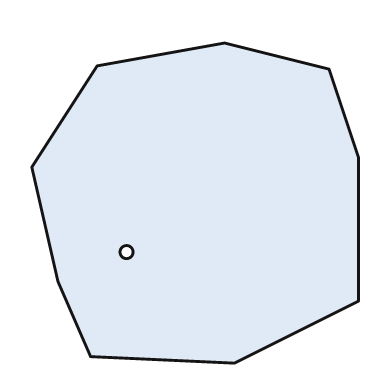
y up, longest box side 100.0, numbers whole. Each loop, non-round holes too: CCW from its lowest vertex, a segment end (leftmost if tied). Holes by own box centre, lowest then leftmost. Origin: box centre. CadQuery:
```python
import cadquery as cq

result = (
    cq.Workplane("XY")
    .moveTo(12.0, -49.0)
    .lineTo(50.0, -30.0)
    .lineTo(50.0, 14.0)
    .lineTo(41.0, 41.0)
    .lineTo(9.0, 49.0)
    .lineTo(-30.0, 42.0)
    .lineTo(-50.0, 11.0)
    .lineTo(-42.0, -24.0)
    .lineTo(-32.0, -47.0)
    .close()
    .moveTo(-21.0, -15.0)
    .circle(2.0)
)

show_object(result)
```